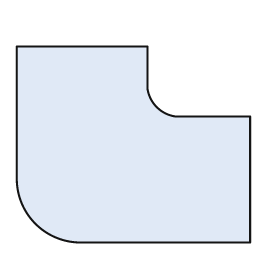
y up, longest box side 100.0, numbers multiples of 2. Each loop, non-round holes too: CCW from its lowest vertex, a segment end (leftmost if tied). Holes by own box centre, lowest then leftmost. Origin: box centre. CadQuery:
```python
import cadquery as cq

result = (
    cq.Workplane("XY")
    .moveTo(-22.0, -42.0)
    .lineTo(50.0, -42.0)
    .lineTo(50.0, 12.0)
    .lineTo(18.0, 12.0)
    .threePointArc((10.0, 16.0), (6.0, 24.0))
    .lineTo(6.0, 42.0)
    .lineTo(-50.0, 42.0)
    .lineTo(-50.0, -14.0)
    .threePointArc((-42.0, -34.0), (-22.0, -42.0))
    .close()
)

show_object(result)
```